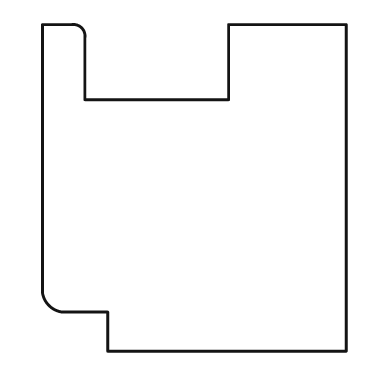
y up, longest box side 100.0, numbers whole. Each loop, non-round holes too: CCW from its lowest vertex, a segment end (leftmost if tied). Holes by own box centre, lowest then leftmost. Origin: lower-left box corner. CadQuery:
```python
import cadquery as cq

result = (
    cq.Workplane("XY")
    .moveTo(20.0, 0.0)
    .lineTo(93.0, 0.0)
    .lineTo(93.0, 100.0)
    .lineTo(57.0, 100.0)
    .lineTo(57.0, 77.0)
    .lineTo(13.0, 77.0)
    .lineTo(13.0, 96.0)
    .threePointArc((12.0, 99.0), (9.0, 100.0))
    .lineTo(0.0, 100.0)
    .lineTo(0.0, 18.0)
    .threePointArc((2.0, 14.0), (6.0, 12.0))
    .lineTo(20.0, 12.0)
    .close()
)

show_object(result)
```